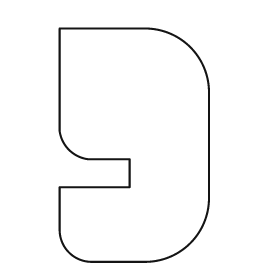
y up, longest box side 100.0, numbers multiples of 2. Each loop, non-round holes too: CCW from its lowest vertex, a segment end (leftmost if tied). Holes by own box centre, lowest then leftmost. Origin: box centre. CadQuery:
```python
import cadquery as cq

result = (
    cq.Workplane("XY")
    .moveTo(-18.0, -50.0)
    .lineTo(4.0, -50.0)
    .threePointArc((24.0, -42.0), (32.0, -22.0))
    .lineTo(32.0, 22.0)
    .threePointArc((24.0, 42.0), (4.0, 50.0))
    .lineTo(-32.0, 50.0)
    .lineTo(-32.0, 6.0)
    .threePointArc((-28.0, -2.0), (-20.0, -6.0))
    .lineTo(-2.0, -6.0)
    .lineTo(-2.0, -18.0)
    .lineTo(-32.0, -18.0)
    .lineTo(-32.0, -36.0)
    .threePointArc((-28.0, -46.0), (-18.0, -50.0))
    .close()
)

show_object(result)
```